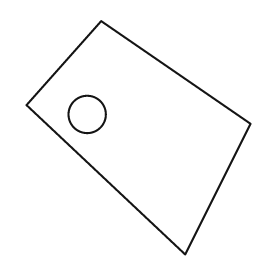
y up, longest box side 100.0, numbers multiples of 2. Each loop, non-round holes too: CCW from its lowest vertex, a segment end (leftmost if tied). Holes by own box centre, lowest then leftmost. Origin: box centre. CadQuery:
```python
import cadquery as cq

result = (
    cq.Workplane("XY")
    .moveTo(20.0, -50.0)
    .lineTo(48.0, 6.0)
    .lineTo(-16.0, 50.0)
    .lineTo(-48.0, 14.0)
    .close()
    .moveTo(-22.0, 10.0)
    .circle(8.0)
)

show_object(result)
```